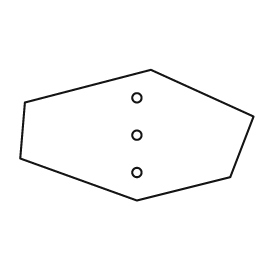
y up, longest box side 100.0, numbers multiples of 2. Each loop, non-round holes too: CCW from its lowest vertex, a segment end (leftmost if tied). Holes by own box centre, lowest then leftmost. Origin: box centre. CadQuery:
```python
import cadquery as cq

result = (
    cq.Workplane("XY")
    .moveTo(0.0, -28.0)
    .lineTo(40.0, -18.0)
    .lineTo(50.0, 8.0)
    .lineTo(6.0, 28.0)
    .lineTo(-48.0, 14.0)
    .lineTo(-50.0, -10.0)
    .close()
    .moveTo(0.0, -16.0)
    .circle(2.0)
    .moveTo(0.0, 0.0)
    .circle(2.0)
    .moveTo(0.0, 16.0)
    .circle(2.0)
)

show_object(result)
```